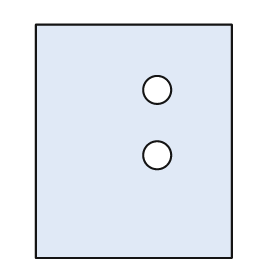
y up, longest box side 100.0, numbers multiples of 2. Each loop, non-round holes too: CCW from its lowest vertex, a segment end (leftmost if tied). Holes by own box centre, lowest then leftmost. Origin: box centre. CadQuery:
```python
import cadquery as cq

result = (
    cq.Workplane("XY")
    .moveTo(-42.0, -50.0)
    .lineTo(42.0, -50.0)
    .lineTo(42.0, 50.0)
    .lineTo(-42.0, 50.0)
    .close()
    .moveTo(10.0, -6.0)
    .circle(6.0)
    .moveTo(10.0, 22.0)
    .circle(6.0)
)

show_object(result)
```